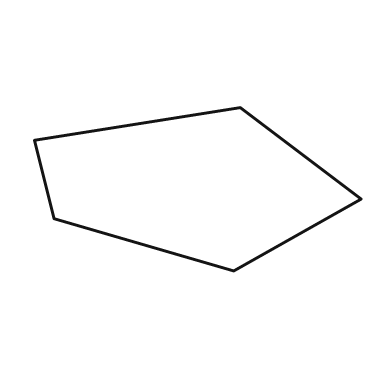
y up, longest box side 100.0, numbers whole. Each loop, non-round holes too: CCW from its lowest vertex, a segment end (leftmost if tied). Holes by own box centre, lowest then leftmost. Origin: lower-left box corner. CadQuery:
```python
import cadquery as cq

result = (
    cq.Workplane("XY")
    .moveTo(61.0, 0.0)
    .lineTo(100.0, 22.0)
    .lineTo(63.0, 50.0)
    .lineTo(0.0, 40.0)
    .lineTo(6.0, 16.0)
    .close()
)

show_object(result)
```